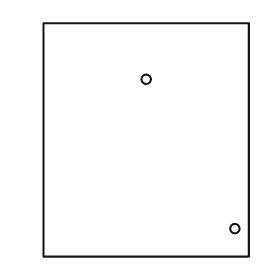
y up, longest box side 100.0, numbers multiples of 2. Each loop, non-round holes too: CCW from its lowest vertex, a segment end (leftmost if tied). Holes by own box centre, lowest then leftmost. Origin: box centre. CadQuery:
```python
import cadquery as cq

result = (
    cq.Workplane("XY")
    .moveTo(-44.0, -50.0)
    .lineTo(44.0, -50.0)
    .lineTo(44.0, 50.0)
    .lineTo(-44.0, 50.0)
    .close()
    .moveTo(38.0, -38.0)
    .circle(2.0)
    .moveTo(0.0, 26.0)
    .circle(2.0)
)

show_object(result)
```